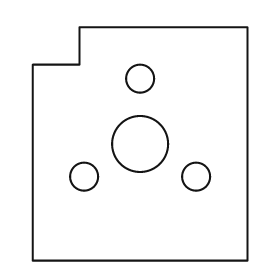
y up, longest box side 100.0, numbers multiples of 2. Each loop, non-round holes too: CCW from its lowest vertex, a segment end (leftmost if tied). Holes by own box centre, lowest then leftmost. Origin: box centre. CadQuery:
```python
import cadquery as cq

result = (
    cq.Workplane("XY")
    .moveTo(-46.0, -50.0)
    .lineTo(46.0, -50.0)
    .lineTo(46.0, 50.0)
    .lineTo(-26.0, 50.0)
    .lineTo(-26.0, 34.0)
    .lineTo(-46.0, 34.0)
    .close()
    .moveTo(-24.0, -14.0)
    .circle(6.0)
    .moveTo(24.0, -14.0)
    .circle(6.0)
    .moveTo(0.0, 0.0)
    .circle(12.0)
    .moveTo(0.0, 28.0)
    .circle(6.0)
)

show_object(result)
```